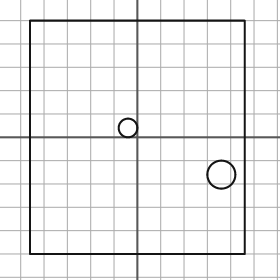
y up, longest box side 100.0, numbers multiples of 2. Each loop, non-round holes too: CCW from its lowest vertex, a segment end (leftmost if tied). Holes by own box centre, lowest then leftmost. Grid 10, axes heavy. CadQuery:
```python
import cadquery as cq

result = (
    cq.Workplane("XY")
    .moveTo(-46.0, -50.0)
    .lineTo(46.0, -50.0)
    .lineTo(46.0, 50.0)
    .lineTo(-46.0, 50.0)
    .close()
    .moveTo(36.0, -16.0)
    .circle(6.0)
    .moveTo(-4.0, 4.0)
    .circle(4.0)
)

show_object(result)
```